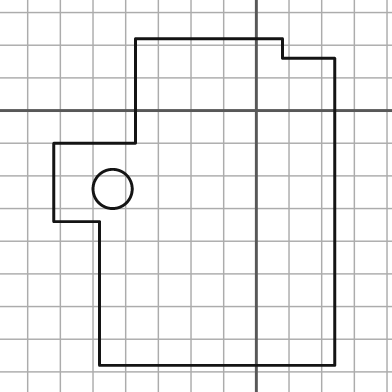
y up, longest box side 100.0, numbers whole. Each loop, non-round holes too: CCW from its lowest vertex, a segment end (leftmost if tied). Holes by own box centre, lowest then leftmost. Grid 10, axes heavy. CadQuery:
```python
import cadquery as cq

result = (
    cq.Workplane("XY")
    .moveTo(-48.0, -78.0)
    .lineTo(24.0, -78.0)
    .lineTo(24.0, 16.0)
    .lineTo(8.0, 16.0)
    .lineTo(8.0, 22.0)
    .lineTo(-37.0, 22.0)
    .lineTo(-37.0, -10.0)
    .lineTo(-62.0, -10.0)
    .lineTo(-62.0, -34.0)
    .lineTo(-48.0, -34.0)
    .close()
    .moveTo(-44.0, -24.0)
    .circle(6.0)
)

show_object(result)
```